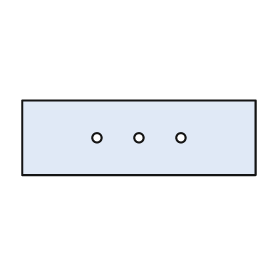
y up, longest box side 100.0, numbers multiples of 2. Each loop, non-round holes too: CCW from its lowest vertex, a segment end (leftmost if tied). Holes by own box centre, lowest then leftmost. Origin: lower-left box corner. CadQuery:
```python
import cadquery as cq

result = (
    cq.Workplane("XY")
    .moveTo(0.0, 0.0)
    .lineTo(100.0, 0.0)
    .lineTo(100.0, 32.0)
    .lineTo(0.0, 32.0)
    .close()
    .moveTo(32.0, 16.0)
    .circle(2.0)
    .moveTo(50.0, 16.0)
    .circle(2.0)
    .moveTo(68.0, 16.0)
    .circle(2.0)
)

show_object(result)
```